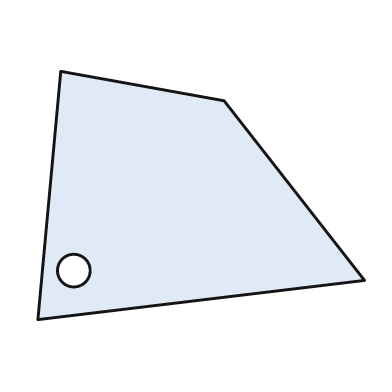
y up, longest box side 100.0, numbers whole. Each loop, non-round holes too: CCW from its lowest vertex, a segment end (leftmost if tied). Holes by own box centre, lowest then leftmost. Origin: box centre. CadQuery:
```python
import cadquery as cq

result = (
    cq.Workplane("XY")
    .moveTo(-50.0, -38.0)
    .lineTo(50.0, -26.0)
    .lineTo(7.0, 29.0)
    .lineTo(-43.0, 38.0)
    .close()
    .moveTo(-39.0, -23.0)
    .circle(5.0)
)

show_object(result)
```